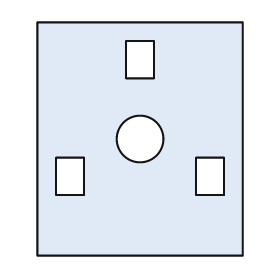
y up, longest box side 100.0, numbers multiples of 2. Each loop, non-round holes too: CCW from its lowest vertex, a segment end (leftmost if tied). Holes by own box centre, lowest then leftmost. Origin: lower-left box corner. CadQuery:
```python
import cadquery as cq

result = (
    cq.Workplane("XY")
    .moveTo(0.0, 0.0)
    .lineTo(88.0, 0.0)
    .lineTo(88.0, 100.0)
    .lineTo(0.0, 100.0)
    .close()
    .moveTo(8.0, 26.0)
    .lineTo(20.0, 26.0)
    .lineTo(20.0, 42.0)
    .lineTo(8.0, 42.0)
    .close()
    .moveTo(68.0, 26.0)
    .lineTo(80.0, 26.0)
    .lineTo(80.0, 42.0)
    .lineTo(68.0, 42.0)
    .close()
    .moveTo(44.0, 50.0)
    .circle(10.0)
    .moveTo(38.0, 76.0)
    .lineTo(50.0, 76.0)
    .lineTo(50.0, 92.0)
    .lineTo(38.0, 92.0)
    .close()
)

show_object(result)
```